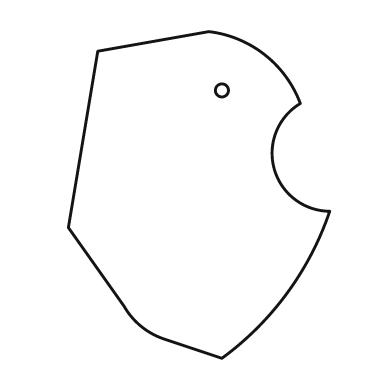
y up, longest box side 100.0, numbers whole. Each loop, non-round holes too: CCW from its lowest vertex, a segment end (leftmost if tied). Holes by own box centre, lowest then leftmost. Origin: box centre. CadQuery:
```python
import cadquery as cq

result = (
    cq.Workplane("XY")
    .moveTo(7.0, -50.0)
    .threePointArc((27.0, -30.0), (40.0, -5.0))
    .threePointArc((23.0, 8.0), (31.0, 28.0))
    .threePointArc((20.0, 43.0), (3.0, 50.0))
    .lineTo(-31.0, 44.0)
    .lineTo(-40.0, -10.0)
    .lineTo(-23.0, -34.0)
    .threePointArc((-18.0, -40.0), (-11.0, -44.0))
    .close()
    .moveTo(7.0, 32.0)
    .circle(2.0)
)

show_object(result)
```